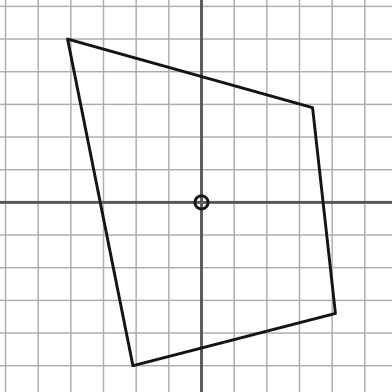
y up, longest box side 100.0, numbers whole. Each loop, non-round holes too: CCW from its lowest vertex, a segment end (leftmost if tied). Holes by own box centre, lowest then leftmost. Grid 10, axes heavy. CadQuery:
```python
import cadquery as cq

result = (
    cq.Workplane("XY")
    .moveTo(-21.0, -50.0)
    .lineTo(41.0, -34.0)
    .lineTo(34.0, 29.0)
    .lineTo(-41.0, 50.0)
    .close()
    .moveTo(0.0, 0.0)
    .circle(2.0)
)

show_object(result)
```